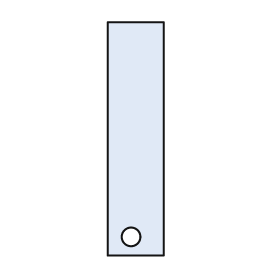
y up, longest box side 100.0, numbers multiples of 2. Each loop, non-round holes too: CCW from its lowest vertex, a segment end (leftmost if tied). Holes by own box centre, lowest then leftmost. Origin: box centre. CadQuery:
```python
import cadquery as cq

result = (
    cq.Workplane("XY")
    .moveTo(-12.0, -50.0)
    .lineTo(12.0, -50.0)
    .lineTo(12.0, 50.0)
    .lineTo(-12.0, 50.0)
    .close()
    .moveTo(-2.0, -42.0)
    .circle(4.0)
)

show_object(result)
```